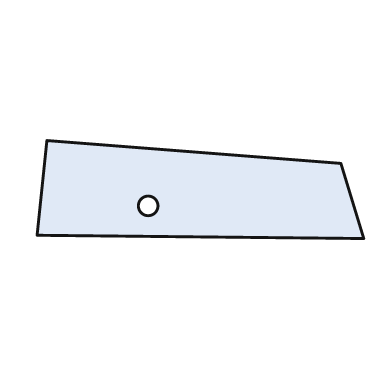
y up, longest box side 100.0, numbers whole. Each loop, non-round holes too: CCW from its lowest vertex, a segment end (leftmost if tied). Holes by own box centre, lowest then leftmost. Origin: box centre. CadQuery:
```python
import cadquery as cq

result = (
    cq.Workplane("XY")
    .moveTo(50.0, -15.0)
    .lineTo(43.0, 8.0)
    .lineTo(-47.0, 15.0)
    .lineTo(-50.0, -14.0)
    .close()
    .moveTo(-16.0, -5.0)
    .circle(3.0)
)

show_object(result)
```